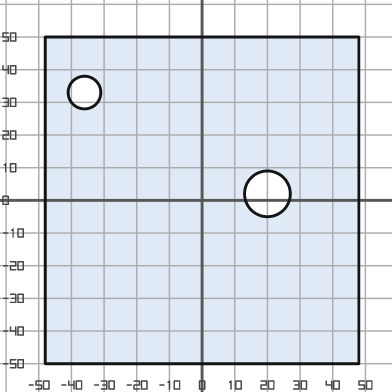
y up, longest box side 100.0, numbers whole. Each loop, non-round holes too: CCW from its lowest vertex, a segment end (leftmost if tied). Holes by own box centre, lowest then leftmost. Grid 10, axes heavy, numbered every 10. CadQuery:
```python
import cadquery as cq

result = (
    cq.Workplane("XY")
    .moveTo(-48.0, -50.0)
    .lineTo(48.0, -50.0)
    .lineTo(48.0, 50.0)
    .lineTo(-48.0, 50.0)
    .close()
    .moveTo(20.0, 2.0)
    .circle(7.0)
    .moveTo(-36.0, 33.0)
    .circle(5.0)
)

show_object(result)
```